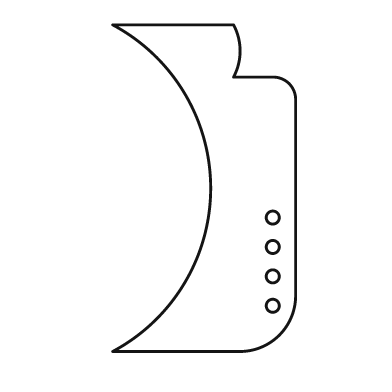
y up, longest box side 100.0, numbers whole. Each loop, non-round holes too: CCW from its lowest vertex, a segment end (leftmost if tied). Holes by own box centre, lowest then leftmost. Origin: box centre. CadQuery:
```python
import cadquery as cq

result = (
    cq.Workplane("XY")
    .moveTo(-28.0, -50.0)
    .lineTo(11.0, -50.0)
    .threePointArc((23.0, -45.0), (28.0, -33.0))
    .lineTo(28.0, 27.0)
    .threePointArc((26.0, 32.0), (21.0, 34.0))
    .lineTo(9.0, 34.0)
    .threePointArc((11.0, 42.0), (9.0, 50.0))
    .lineTo(-28.0, 50.0)
    .threePointArc((2.0, 0.0), (-28.0, -50.0))
    .close()
    .moveTo(21.0, -36.0)
    .circle(2.0)
    .moveTo(21.0, -27.0)
    .circle(2.0)
    .moveTo(21.0, -18.0)
    .circle(2.0)
    .moveTo(21.0, -9.0)
    .circle(2.0)
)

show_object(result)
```